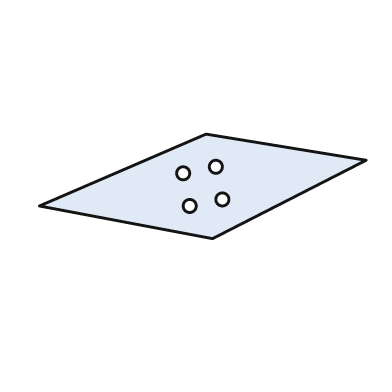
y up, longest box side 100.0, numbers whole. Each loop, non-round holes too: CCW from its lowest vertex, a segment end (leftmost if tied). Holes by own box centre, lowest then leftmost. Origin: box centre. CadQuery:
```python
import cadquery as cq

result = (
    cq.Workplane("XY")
    .moveTo(3.0, -16.0)
    .lineTo(50.0, 8.0)
    .lineTo(1.0, 16.0)
    .lineTo(-50.0, -6.0)
    .close()
    .moveTo(-4.0, -6.0)
    .circle(2.0)
    .moveTo(6.0, -4.0)
    .circle(2.0)
    .moveTo(-6.0, 4.0)
    .circle(2.0)
    .moveTo(4.0, 6.0)
    .circle(2.0)
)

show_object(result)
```